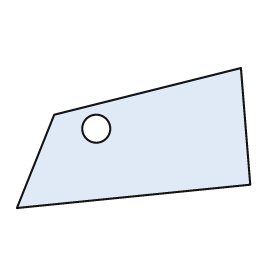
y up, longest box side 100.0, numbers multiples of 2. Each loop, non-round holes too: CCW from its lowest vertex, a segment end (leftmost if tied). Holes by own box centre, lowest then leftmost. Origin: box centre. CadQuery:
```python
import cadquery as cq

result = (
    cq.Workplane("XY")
    .moveTo(-50.0, -30.0)
    .lineTo(50.0, -20.0)
    .lineTo(46.0, 30.0)
    .lineTo(-34.0, 10.0)
    .close()
    .moveTo(-16.0, 4.0)
    .circle(6.0)
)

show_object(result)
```